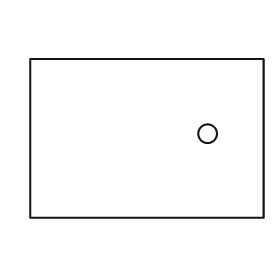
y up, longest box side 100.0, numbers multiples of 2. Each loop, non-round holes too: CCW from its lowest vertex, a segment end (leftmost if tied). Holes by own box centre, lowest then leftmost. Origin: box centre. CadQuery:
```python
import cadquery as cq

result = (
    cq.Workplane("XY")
    .moveTo(-50.0, -34.0)
    .lineTo(50.0, -34.0)
    .lineTo(50.0, 34.0)
    .lineTo(-50.0, 34.0)
    .close()
    .moveTo(26.0, 2.0)
    .circle(4.0)
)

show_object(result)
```